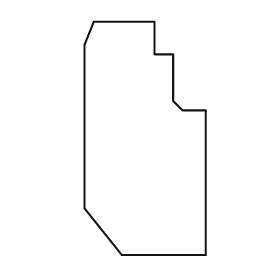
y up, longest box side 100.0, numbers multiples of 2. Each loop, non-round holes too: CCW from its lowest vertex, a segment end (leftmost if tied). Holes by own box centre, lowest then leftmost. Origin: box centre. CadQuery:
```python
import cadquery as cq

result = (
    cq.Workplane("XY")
    .moveTo(-10.0, -50.0)
    .lineTo(26.0, -50.0)
    .lineTo(26.0, 12.0)
    .lineTo(16.0, 12.0)
    .lineTo(12.0, 16.0)
    .lineTo(12.0, 36.0)
    .lineTo(4.0, 36.0)
    .lineTo(4.0, 50.0)
    .lineTo(-22.0, 50.0)
    .lineTo(-26.0, 40.0)
    .lineTo(-26.0, -30.0)
    .close()
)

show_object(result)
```